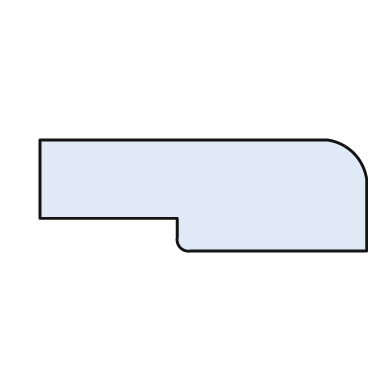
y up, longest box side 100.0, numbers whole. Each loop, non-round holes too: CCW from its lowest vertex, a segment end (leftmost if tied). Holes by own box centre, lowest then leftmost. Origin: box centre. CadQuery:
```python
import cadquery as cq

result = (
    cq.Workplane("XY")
    .moveTo(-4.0, -17.0)
    .lineTo(50.0, -17.0)
    .lineTo(50.0, 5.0)
    .threePointArc((46.0, 13.0), (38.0, 17.0))
    .lineTo(-50.0, 17.0)
    .lineTo(-50.0, -7.0)
    .lineTo(-8.0, -7.0)
    .lineTo(-8.0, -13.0)
    .threePointArc((-7.0, -16.0), (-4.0, -17.0))
    .close()
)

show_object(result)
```